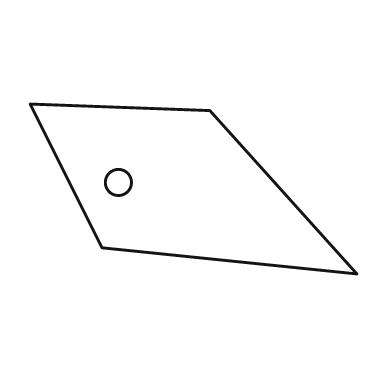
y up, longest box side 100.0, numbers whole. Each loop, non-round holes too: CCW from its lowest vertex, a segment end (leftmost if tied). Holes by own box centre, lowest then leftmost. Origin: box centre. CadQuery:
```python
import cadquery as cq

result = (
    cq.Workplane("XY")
    .moveTo(50.0, -26.0)
    .lineTo(5.0, 24.0)
    .lineTo(-50.0, 26.0)
    .lineTo(-28.0, -18.0)
    .close()
    .moveTo(-23.0, 2.0)
    .circle(4.0)
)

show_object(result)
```